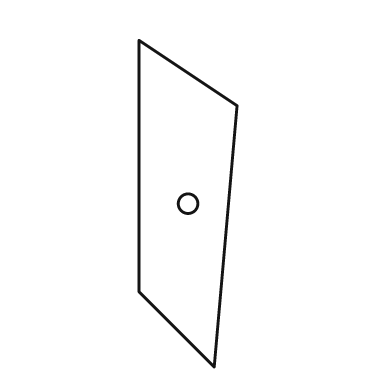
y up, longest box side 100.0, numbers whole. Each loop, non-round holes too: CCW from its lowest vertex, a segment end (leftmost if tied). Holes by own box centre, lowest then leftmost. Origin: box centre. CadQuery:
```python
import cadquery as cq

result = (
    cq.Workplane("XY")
    .moveTo(8.0, -50.0)
    .lineTo(15.0, 30.0)
    .lineTo(-15.0, 50.0)
    .lineTo(-15.0, -27.0)
    .close()
    .moveTo(0.0, 0.0)
    .circle(3.0)
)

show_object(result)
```